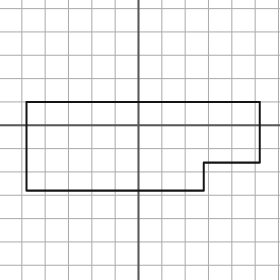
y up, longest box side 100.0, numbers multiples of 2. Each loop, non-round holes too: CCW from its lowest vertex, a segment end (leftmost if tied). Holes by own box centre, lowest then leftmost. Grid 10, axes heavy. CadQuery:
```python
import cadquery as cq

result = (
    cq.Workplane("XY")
    .moveTo(-48.0, -28.0)
    .lineTo(28.0, -28.0)
    .lineTo(28.0, -16.0)
    .lineTo(52.0, -16.0)
    .lineTo(52.0, 10.0)
    .lineTo(-48.0, 10.0)
    .close()
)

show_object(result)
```